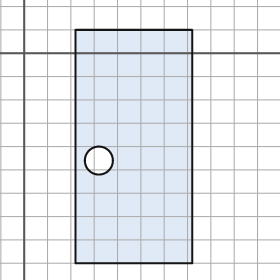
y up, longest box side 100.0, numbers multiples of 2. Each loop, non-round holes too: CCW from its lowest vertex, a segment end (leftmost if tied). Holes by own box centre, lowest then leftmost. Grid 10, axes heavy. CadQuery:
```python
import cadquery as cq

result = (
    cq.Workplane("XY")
    .moveTo(22.0, -90.0)
    .lineTo(72.0, -90.0)
    .lineTo(72.0, 10.0)
    .lineTo(22.0, 10.0)
    .close()
    .moveTo(32.0, -46.0)
    .circle(6.0)
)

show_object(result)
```